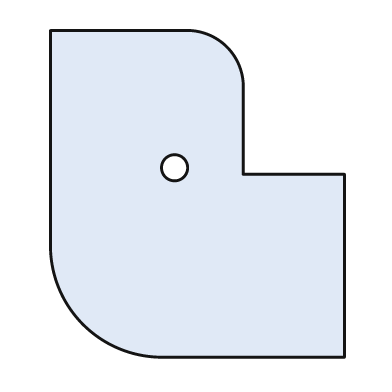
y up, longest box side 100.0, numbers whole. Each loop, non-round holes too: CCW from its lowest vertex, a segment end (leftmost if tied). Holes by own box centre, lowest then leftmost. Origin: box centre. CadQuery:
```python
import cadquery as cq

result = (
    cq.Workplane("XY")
    .moveTo(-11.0, -50.0)
    .lineTo(45.0, -50.0)
    .lineTo(45.0, 6.0)
    .lineTo(14.0, 6.0)
    .lineTo(14.0, 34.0)
    .threePointArc((9.0, 45.0), (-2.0, 50.0))
    .lineTo(-45.0, 50.0)
    .lineTo(-45.0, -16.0)
    .threePointArc((-35.0, -40.0), (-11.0, -50.0))
    .close()
    .moveTo(-7.0, 8.0)
    .circle(4.0)
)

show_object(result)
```